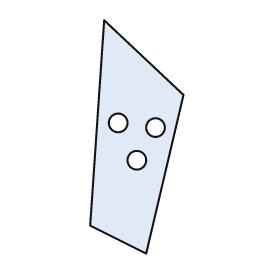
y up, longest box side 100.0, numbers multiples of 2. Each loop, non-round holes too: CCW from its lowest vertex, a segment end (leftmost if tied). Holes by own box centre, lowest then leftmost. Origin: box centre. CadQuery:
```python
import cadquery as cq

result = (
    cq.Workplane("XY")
    .moveTo(4.0, -50.0)
    .lineTo(20.0, 18.0)
    .lineTo(-14.0, 50.0)
    .lineTo(-20.0, -38.0)
    .close()
    .moveTo(0.0, -10.0)
    .circle(4.0)
    .moveTo(8.0, 4.0)
    .circle(4.0)
    .moveTo(-8.0, 6.0)
    .circle(4.0)
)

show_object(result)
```